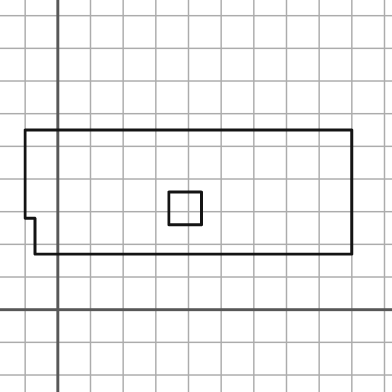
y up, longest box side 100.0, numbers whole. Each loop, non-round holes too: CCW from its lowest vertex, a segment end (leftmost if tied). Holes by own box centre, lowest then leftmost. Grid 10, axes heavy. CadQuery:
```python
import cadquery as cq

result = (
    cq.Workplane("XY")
    .moveTo(-7.0, 17.0)
    .lineTo(90.0, 17.0)
    .lineTo(90.0, 55.0)
    .lineTo(-10.0, 55.0)
    .lineTo(-10.0, 28.0)
    .lineTo(-7.0, 28.0)
    .close()
    .moveTo(34.0, 26.0)
    .lineTo(44.0, 26.0)
    .lineTo(44.0, 36.0)
    .lineTo(34.0, 36.0)
    .close()
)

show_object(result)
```